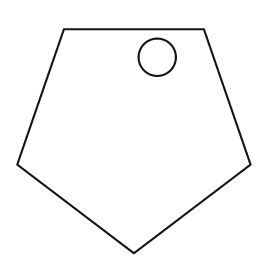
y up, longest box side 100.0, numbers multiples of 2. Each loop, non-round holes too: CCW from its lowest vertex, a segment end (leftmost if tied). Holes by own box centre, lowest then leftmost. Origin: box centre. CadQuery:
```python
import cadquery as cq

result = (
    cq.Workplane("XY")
    .moveTo(0.0, -48.0)
    .lineTo(50.0, -10.0)
    .lineTo(30.0, 48.0)
    .lineTo(-30.0, 48.0)
    .lineTo(-50.0, -10.0)
    .close()
    .moveTo(10.0, 36.0)
    .circle(8.0)
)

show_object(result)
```